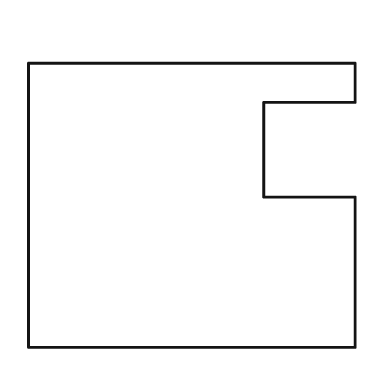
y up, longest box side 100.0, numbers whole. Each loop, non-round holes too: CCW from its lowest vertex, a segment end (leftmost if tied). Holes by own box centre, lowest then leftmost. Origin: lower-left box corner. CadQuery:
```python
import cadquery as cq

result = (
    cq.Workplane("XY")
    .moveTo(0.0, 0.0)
    .lineTo(100.0, 0.0)
    .lineTo(100.0, 46.0)
    .lineTo(72.0, 46.0)
    .lineTo(72.0, 75.0)
    .lineTo(100.0, 75.0)
    .lineTo(100.0, 87.0)
    .lineTo(0.0, 87.0)
    .close()
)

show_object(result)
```